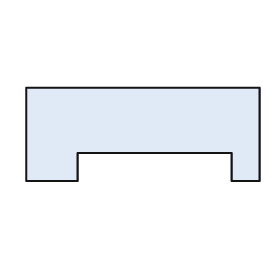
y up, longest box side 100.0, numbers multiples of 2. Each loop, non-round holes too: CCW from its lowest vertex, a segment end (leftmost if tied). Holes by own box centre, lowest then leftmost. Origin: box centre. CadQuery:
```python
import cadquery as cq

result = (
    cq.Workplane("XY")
    .moveTo(-50.0, -20.0)
    .lineTo(-28.0, -20.0)
    .lineTo(-28.0, -8.0)
    .lineTo(38.0, -8.0)
    .lineTo(38.0, -20.0)
    .lineTo(50.0, -20.0)
    .lineTo(50.0, 20.0)
    .lineTo(-50.0, 20.0)
    .close()
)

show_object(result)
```